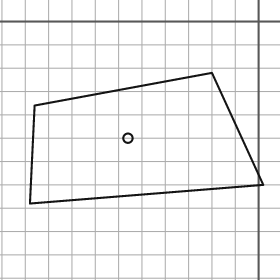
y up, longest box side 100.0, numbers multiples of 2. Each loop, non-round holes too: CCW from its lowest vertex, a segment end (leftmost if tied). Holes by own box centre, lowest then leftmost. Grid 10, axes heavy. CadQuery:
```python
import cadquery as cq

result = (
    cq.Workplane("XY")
    .moveTo(-98.0, -78.0)
    .lineTo(2.0, -70.0)
    .lineTo(-20.0, -22.0)
    .lineTo(-96.0, -36.0)
    .close()
    .moveTo(-56.0, -50.0)
    .circle(2.0)
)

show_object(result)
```